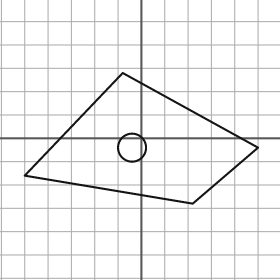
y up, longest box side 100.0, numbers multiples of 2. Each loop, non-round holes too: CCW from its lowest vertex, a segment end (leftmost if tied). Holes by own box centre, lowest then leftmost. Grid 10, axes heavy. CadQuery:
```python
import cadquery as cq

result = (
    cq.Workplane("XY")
    .moveTo(22.0, -28.0)
    .lineTo(50.0, -4.0)
    .lineTo(-8.0, 28.0)
    .lineTo(-50.0, -16.0)
    .close()
    .moveTo(-4.0, -4.0)
    .circle(6.0)
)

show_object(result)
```